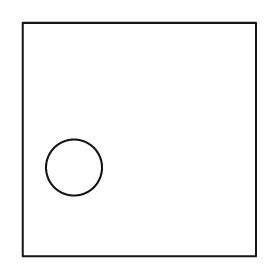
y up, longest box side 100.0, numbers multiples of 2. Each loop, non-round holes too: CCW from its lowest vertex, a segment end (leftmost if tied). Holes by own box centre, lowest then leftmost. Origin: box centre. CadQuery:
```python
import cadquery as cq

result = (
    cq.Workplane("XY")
    .moveTo(-50.0, -50.0)
    .lineTo(50.0, -50.0)
    .lineTo(50.0, 50.0)
    .lineTo(-50.0, 50.0)
    .close()
    .moveTo(-28.0, -12.0)
    .circle(12.0)
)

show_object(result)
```